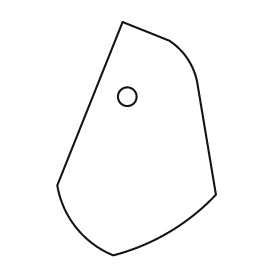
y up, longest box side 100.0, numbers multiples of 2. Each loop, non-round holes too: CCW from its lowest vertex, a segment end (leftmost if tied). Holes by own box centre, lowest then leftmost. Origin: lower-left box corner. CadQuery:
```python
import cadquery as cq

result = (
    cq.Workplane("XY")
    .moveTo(24.0, 0.0)
    .threePointArc((48.0, 10.0), (68.0, 26.0))
    .lineTo(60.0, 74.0)
    .threePointArc((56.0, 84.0), (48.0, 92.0))
    .lineTo(28.0, 100.0)
    .lineTo(0.0, 30.0)
    .threePointArc((8.0, 12.0), (24.0, 0.0))
    .close()
    .moveTo(30.0, 68.0)
    .circle(4.0)
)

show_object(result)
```